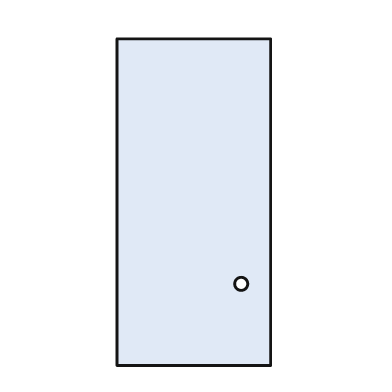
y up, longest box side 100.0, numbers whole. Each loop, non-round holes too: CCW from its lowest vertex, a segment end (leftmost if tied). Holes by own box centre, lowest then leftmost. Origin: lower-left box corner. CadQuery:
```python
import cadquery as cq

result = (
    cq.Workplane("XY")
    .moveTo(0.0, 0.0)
    .lineTo(47.0, 0.0)
    .lineTo(47.0, 100.0)
    .lineTo(0.0, 100.0)
    .close()
    .moveTo(38.0, 25.0)
    .circle(2.0)
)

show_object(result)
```